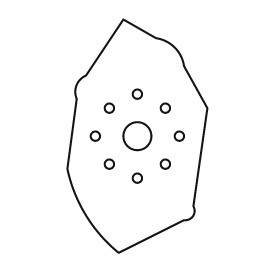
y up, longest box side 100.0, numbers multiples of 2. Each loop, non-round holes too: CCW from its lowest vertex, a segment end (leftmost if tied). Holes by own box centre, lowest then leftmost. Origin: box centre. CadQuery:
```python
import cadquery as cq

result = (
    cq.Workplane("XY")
    .moveTo(-8.0, -50.0)
    .lineTo(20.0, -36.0)
    .threePointArc((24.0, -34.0), (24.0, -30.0))
    .lineTo(30.0, 12.0)
    .lineTo(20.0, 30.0)
    .threePointArc((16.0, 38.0), (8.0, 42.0))
    .lineTo(-6.0, 50.0)
    .lineTo(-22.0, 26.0)
    .threePointArc((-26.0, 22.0), (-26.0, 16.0))
    .lineTo(-30.0, -14.0)
    .threePointArc((-22.0, -34.0), (-8.0, -50.0))
    .close()
    .moveTo(0.0, -18.0)
    .circle(2.0)
    .moveTo(-12.0, -12.0)
    .circle(2.0)
    .moveTo(12.0, -12.0)
    .circle(2.0)
    .moveTo(-18.0, 0.0)
    .circle(2.0)
    .moveTo(0.0, 0.0)
    .circle(6.0)
    .moveTo(18.0, 0.0)
    .circle(2.0)
    .moveTo(-12.0, 12.0)
    .circle(2.0)
    .moveTo(12.0, 12.0)
    .circle(2.0)
    .moveTo(0.0, 18.0)
    .circle(2.0)
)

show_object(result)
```